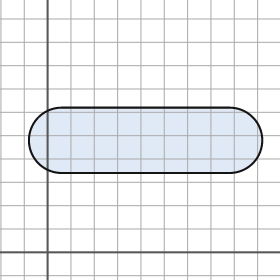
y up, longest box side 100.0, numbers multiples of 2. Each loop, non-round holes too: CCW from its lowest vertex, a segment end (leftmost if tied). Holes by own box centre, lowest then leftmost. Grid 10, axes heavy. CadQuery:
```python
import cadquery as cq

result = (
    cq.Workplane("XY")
    .moveTo(6.0, 34.0)
    .lineTo(78.0, 34.0)
    .threePointArc((92.0, 48.0), (78.0, 62.0))
    .lineTo(6.0, 62.0)
    .threePointArc((-8.0, 48.0), (6.0, 34.0))
    .close()
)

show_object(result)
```